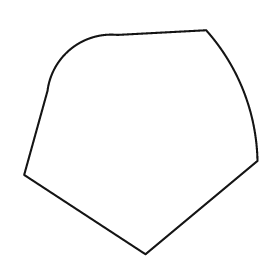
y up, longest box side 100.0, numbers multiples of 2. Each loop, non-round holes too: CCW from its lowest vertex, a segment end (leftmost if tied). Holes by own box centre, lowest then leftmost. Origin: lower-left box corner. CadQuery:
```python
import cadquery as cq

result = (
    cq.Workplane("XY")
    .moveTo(52.0, 0.0)
    .lineTo(100.0, 40.0)
    .threePointArc((94.0, 70.0), (78.0, 96.0))
    .lineTo(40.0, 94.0)
    .threePointArc((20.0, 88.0), (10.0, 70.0))
    .lineTo(0.0, 34.0)
    .close()
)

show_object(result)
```